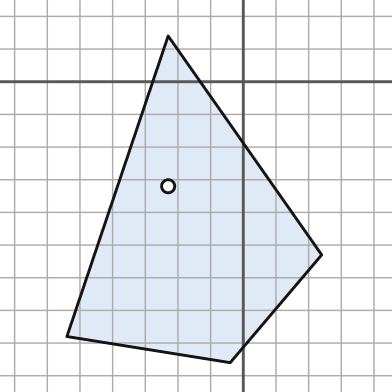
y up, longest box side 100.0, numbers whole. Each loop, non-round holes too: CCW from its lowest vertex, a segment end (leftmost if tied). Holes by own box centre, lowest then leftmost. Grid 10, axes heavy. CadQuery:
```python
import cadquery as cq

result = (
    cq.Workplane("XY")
    .moveTo(-4.0, -86.0)
    .lineTo(24.0, -53.0)
    .lineTo(-23.0, 14.0)
    .lineTo(-54.0, -78.0)
    .close()
    .moveTo(-23.0, -32.0)
    .circle(2.0)
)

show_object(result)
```